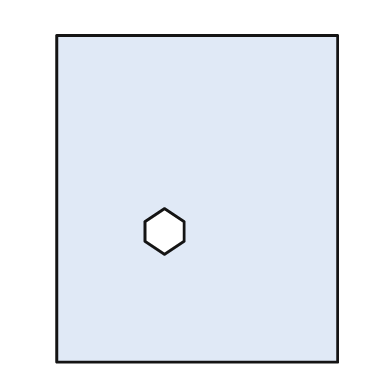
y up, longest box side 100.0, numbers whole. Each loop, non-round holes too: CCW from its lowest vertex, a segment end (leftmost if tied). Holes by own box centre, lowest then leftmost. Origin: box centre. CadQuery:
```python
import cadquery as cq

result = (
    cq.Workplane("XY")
    .moveTo(-43.0, -50.0)
    .lineTo(43.0, -50.0)
    .lineTo(43.0, 50.0)
    .lineTo(-43.0, 50.0)
    .close()
    .moveTo(-10.0, -17.0)
    .lineTo(-4.0, -13.0)
    .lineTo(-4.0, -7.0)
    .lineTo(-10.0, -3.0)
    .lineTo(-16.0, -7.0)
    .lineTo(-16.0, -13.0)
    .close()
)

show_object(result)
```